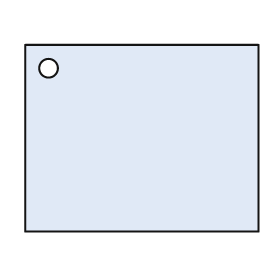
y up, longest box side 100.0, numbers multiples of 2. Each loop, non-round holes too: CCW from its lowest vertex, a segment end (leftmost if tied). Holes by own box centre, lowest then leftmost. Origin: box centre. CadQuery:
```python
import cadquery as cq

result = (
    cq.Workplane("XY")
    .moveTo(-50.0, -40.0)
    .lineTo(50.0, -40.0)
    .lineTo(50.0, 40.0)
    .lineTo(-50.0, 40.0)
    .close()
    .moveTo(-40.0, 30.0)
    .circle(4.0)
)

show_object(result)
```